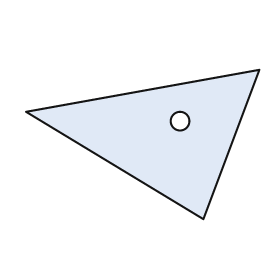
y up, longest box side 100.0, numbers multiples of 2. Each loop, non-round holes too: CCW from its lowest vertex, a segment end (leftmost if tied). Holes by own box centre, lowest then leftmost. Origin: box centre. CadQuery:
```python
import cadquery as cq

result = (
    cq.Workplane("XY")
    .moveTo(26.0, -32.0)
    .lineTo(50.0, 32.0)
    .lineTo(-50.0, 14.0)
    .close()
    .moveTo(16.0, 10.0)
    .circle(4.0)
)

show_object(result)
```